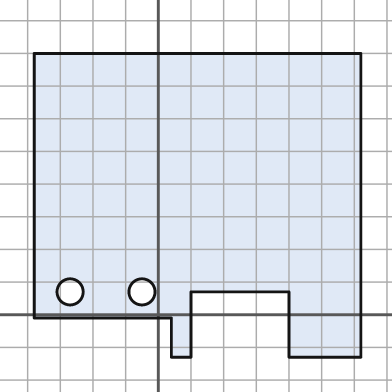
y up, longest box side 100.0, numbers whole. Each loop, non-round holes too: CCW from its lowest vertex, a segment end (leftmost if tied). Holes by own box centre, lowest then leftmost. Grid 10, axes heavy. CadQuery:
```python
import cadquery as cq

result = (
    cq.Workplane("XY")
    .moveTo(4.0, -13.0)
    .lineTo(10.0, -13.0)
    .lineTo(10.0, 7.0)
    .lineTo(40.0, 7.0)
    .lineTo(40.0, -13.0)
    .lineTo(62.0, -13.0)
    .lineTo(62.0, 80.0)
    .lineTo(-38.0, 80.0)
    .lineTo(-38.0, -1.0)
    .lineTo(4.0, -1.0)
    .close()
    .moveTo(-27.0, 7.0)
    .circle(4.0)
    .moveTo(-5.0, 7.0)
    .circle(4.0)
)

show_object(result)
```